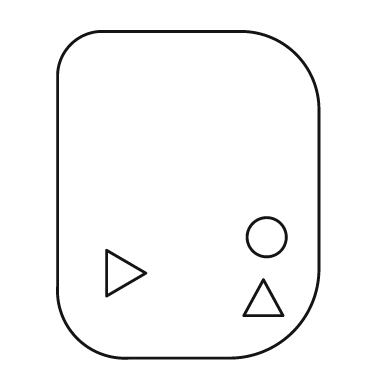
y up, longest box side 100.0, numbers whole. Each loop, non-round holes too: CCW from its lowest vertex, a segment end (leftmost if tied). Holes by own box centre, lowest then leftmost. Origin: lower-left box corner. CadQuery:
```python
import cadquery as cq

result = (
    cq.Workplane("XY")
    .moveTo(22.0, 0.0)
    .lineTo(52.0, 0.0)
    .threePointArc((72.0, 8.0), (80.0, 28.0))
    .lineTo(80.0, 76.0)
    .threePointArc((73.0, 93.0), (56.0, 100.0))
    .lineTo(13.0, 100.0)
    .threePointArc((4.0, 96.0), (0.0, 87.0))
    .lineTo(0.0, 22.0)
    .threePointArc((6.0, 6.0), (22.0, 0.0))
    .close()
    .moveTo(57.0, 13.0)
    .lineTo(69.0, 13.0)
    .lineTo(63.0, 24.0)
    .close()
    .moveTo(15.0, 19.0)
    .lineTo(27.0, 26.0)
    .lineTo(15.0, 33.0)
    .close()
    .moveTo(64.0, 37.0)
    .circle(6.0)
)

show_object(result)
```